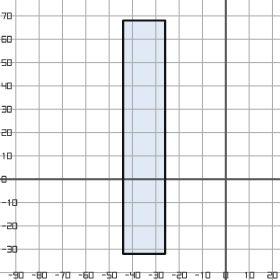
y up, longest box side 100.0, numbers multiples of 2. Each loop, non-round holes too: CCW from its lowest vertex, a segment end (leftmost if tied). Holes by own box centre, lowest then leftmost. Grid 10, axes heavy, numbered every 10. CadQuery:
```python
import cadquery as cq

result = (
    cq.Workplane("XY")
    .moveTo(-44.0, -32.0)
    .lineTo(-26.0, -32.0)
    .lineTo(-26.0, 68.0)
    .lineTo(-44.0, 68.0)
    .close()
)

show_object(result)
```